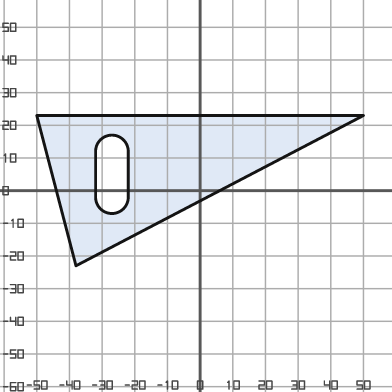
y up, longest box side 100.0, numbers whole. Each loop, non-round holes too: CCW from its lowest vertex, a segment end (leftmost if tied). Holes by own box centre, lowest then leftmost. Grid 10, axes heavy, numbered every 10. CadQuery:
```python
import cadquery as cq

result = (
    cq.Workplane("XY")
    .moveTo(-38.0, -23.0)
    .lineTo(50.0, 23.0)
    .lineTo(-50.0, 23.0)
    .close()
    .moveTo(-32.0, -2.0)
    .threePointArc((-27.0, -7.0), (-22.0, -2.0))
    .lineTo(-22.0, 12.0)
    .threePointArc((-27.0, 17.0), (-32.0, 12.0))
    .close()
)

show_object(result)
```